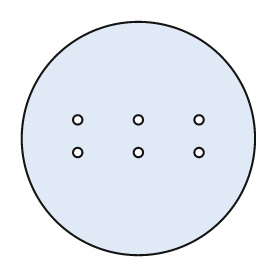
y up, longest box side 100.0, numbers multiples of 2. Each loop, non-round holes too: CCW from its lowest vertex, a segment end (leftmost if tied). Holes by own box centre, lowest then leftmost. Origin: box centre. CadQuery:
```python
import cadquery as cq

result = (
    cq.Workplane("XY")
    .moveTo(0.0, 0.0)
    .circle(50.0)
    .moveTo(-26.0, -6.0)
    .circle(2.0)
    .moveTo(0.0, -6.0)
    .circle(2.0)
    .moveTo(26.0, -6.0)
    .circle(2.0)
    .moveTo(-26.0, 8.0)
    .circle(2.0)
    .moveTo(0.0, 8.0)
    .circle(2.0)
    .moveTo(26.0, 8.0)
    .circle(2.0)
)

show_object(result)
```